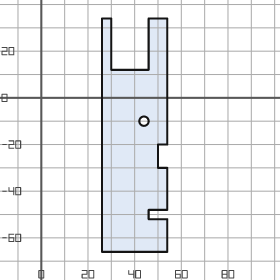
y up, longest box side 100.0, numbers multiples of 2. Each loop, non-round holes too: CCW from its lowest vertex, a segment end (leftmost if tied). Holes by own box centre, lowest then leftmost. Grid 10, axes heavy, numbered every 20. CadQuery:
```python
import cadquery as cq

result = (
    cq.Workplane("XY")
    .moveTo(26.0, -66.0)
    .lineTo(54.0, -66.0)
    .lineTo(54.0, -52.0)
    .lineTo(46.0, -52.0)
    .lineTo(46.0, -48.0)
    .lineTo(54.0, -48.0)
    .lineTo(54.0, -30.0)
    .lineTo(50.0, -30.0)
    .lineTo(50.0, -20.0)
    .lineTo(54.0, -20.0)
    .lineTo(54.0, 34.0)
    .lineTo(46.0, 34.0)
    .lineTo(46.0, 12.0)
    .lineTo(30.0, 12.0)
    .lineTo(30.0, 34.0)
    .lineTo(26.0, 34.0)
    .close()
    .moveTo(44.0, -10.0)
    .circle(2.0)
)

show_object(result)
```